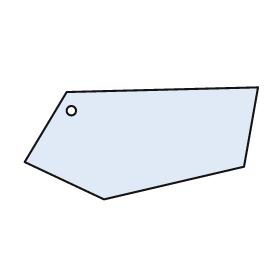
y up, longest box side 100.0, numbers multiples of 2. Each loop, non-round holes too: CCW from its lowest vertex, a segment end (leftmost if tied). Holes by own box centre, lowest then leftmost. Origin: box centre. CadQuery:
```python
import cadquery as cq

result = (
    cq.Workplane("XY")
    .moveTo(-16.0, -24.0)
    .lineTo(44.0, -10.0)
    .lineTo(50.0, 24.0)
    .lineTo(-32.0, 22.0)
    .lineTo(-50.0, -8.0)
    .close()
    .moveTo(-30.0, 14.0)
    .circle(2.0)
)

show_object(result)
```